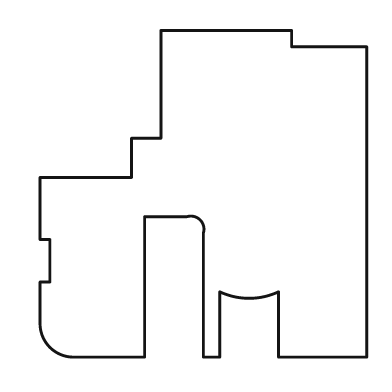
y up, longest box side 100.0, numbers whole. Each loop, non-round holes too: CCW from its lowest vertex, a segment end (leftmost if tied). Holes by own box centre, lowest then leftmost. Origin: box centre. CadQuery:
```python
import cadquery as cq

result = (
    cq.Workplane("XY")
    .moveTo(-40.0, -50.0)
    .lineTo(-18.0, -50.0)
    .lineTo(-18.0, -7.0)
    .lineTo(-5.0, -7.0)
    .threePointArc((-1.0, -8.0), (0.0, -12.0))
    .lineTo(0.0, -50.0)
    .lineTo(5.0, -50.0)
    .lineTo(5.0, -30.0)
    .threePointArc((14.0, -32.0), (23.0, -30.0))
    .lineTo(23.0, -50.0)
    .lineTo(50.0, -50.0)
    .lineTo(50.0, 45.0)
    .lineTo(27.0, 45.0)
    .lineTo(27.0, 50.0)
    .lineTo(-13.0, 50.0)
    .lineTo(-13.0, 17.0)
    .lineTo(-22.0, 17.0)
    .lineTo(-22.0, 5.0)
    .lineTo(-50.0, 5.0)
    .lineTo(-50.0, -14.0)
    .lineTo(-47.0, -14.0)
    .lineTo(-47.0, -27.0)
    .lineTo(-50.0, -27.0)
    .lineTo(-50.0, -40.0)
    .threePointArc((-47.0, -47.0), (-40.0, -50.0))
    .close()
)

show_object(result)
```